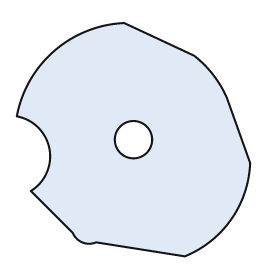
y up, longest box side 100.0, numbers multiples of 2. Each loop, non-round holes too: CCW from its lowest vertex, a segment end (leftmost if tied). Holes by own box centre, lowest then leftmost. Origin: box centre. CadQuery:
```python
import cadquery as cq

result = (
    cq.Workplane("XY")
    .moveTo(22.0, -50.0)
    .threePointArc((42.0, -34.0), (50.0, -10.0))
    .lineTo(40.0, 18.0)
    .threePointArc((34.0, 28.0), (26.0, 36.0))
    .lineTo(-4.0, 50.0)
    .threePointArc((-34.0, 38.0), (-50.0, 10.0))
    .threePointArc((-36.0, -4.0), (-44.0, -22.0))
    .lineTo(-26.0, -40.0)
    .threePointArc((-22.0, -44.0), (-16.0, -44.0))
    .close()
    .moveTo(0.0, 0.0)
    .circle(8.0)
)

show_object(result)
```